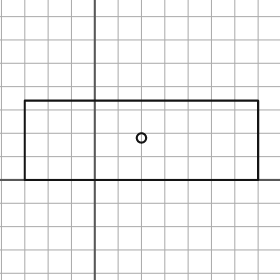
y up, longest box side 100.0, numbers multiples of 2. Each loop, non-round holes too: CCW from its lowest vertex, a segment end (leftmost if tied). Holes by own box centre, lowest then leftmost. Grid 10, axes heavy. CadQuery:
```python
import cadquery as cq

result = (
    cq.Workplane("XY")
    .moveTo(-30.0, 0.0)
    .lineTo(70.0, 0.0)
    .lineTo(70.0, 34.0)
    .lineTo(-30.0, 34.0)
    .close()
    .moveTo(20.0, 18.0)
    .circle(2.0)
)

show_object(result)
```